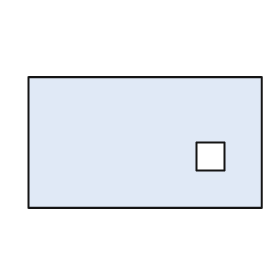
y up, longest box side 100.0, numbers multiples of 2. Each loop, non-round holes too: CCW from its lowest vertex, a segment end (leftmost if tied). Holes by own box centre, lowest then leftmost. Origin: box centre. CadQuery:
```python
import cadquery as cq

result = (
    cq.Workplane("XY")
    .moveTo(-50.0, -28.0)
    .lineTo(50.0, -28.0)
    .lineTo(50.0, 28.0)
    .lineTo(-50.0, 28.0)
    .close()
    .moveTo(22.0, -12.0)
    .lineTo(34.0, -12.0)
    .lineTo(34.0, 0.0)
    .lineTo(22.0, 0.0)
    .close()
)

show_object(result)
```